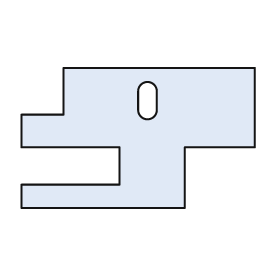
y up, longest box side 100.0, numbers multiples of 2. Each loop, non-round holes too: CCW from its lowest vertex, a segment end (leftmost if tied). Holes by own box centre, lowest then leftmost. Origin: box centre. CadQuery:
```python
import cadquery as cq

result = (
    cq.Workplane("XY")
    .moveTo(-50.0, -30.0)
    .lineTo(20.0, -30.0)
    .lineTo(20.0, -4.0)
    .lineTo(50.0, -4.0)
    .lineTo(50.0, 30.0)
    .lineTo(-32.0, 30.0)
    .lineTo(-32.0, 10.0)
    .lineTo(-50.0, 10.0)
    .lineTo(-50.0, -4.0)
    .lineTo(-8.0, -4.0)
    .lineTo(-8.0, -20.0)
    .lineTo(-50.0, -20.0)
    .close()
    .moveTo(0.0, 12.0)
    .threePointArc((4.0, 8.0), (8.0, 12.0))
    .lineTo(8.0, 20.0)
    .threePointArc((4.0, 24.0), (0.0, 20.0))
    .close()
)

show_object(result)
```